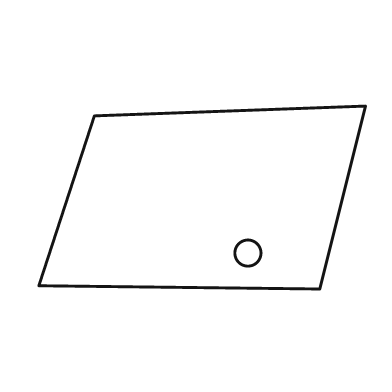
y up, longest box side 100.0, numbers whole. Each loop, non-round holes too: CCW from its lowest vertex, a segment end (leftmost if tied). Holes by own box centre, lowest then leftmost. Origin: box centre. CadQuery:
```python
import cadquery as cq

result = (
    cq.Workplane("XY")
    .moveTo(36.0, -28.0)
    .lineTo(50.0, 28.0)
    .lineTo(-33.0, 25.0)
    .lineTo(-50.0, -27.0)
    .close()
    .moveTo(14.0, -17.0)
    .circle(4.0)
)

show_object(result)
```